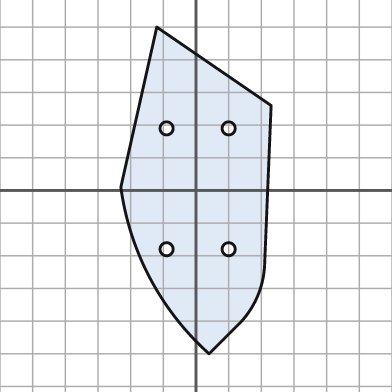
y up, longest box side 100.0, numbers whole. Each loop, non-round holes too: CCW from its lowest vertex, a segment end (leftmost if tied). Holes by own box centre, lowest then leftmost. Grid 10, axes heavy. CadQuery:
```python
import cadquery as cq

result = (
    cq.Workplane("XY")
    .moveTo(4.0, -50.0)
    .lineTo(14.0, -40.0)
    .threePointArc((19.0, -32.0), (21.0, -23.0))
    .lineTo(23.0, 26.0)
    .lineTo(-12.0, 50.0)
    .lineTo(-23.0, 1.0)
    .threePointArc((-14.0, -27.0), (4.0, -50.0))
    .close()
    .moveTo(-9.0, -18.0)
    .circle(2.0)
    .moveTo(10.0, -18.0)
    .circle(2.0)
    .moveTo(-9.0, 19.0)
    .circle(2.0)
    .moveTo(10.0, 19.0)
    .circle(2.0)
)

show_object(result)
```